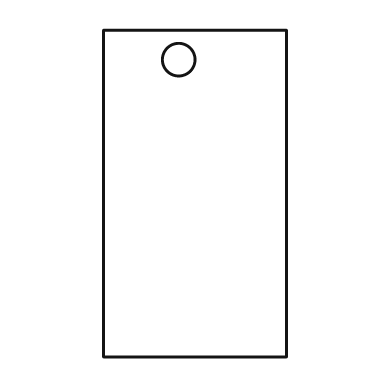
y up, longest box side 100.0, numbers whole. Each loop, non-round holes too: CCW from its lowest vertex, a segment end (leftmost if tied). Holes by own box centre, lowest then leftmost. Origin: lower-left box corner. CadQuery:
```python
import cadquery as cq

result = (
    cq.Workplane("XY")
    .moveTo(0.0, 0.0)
    .lineTo(56.0, 0.0)
    .lineTo(56.0, 100.0)
    .lineTo(0.0, 100.0)
    .close()
    .moveTo(23.0, 91.0)
    .circle(5.0)
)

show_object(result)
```